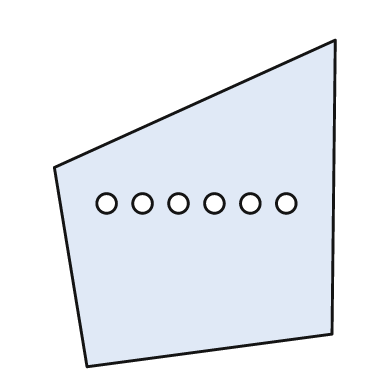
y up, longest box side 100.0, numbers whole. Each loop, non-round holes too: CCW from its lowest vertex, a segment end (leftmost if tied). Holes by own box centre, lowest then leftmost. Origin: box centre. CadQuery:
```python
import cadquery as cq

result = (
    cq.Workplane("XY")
    .moveTo(-33.0, -50.0)
    .lineTo(42.0, -40.0)
    .lineTo(43.0, 50.0)
    .lineTo(-43.0, 11.0)
    .close()
    .moveTo(-27.0, 0.0)
    .circle(3.0)
    .moveTo(-16.0, 0.0)
    .circle(3.0)
    .moveTo(-5.0, 0.0)
    .circle(3.0)
    .moveTo(6.0, 0.0)
    .circle(3.0)
    .moveTo(17.0, 0.0)
    .circle(3.0)
    .moveTo(28.0, 0.0)
    .circle(3.0)
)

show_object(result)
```